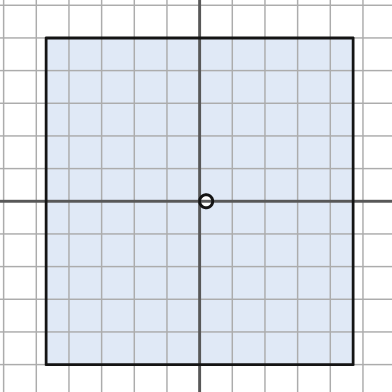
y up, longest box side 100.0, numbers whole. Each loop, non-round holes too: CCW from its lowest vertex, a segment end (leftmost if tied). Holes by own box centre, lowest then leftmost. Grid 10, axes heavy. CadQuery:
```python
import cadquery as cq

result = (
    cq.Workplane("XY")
    .moveTo(-47.0, -50.0)
    .lineTo(47.0, -50.0)
    .lineTo(47.0, 50.0)
    .lineTo(-47.0, 50.0)
    .close()
    .moveTo(2.0, 0.0)
    .circle(2.0)
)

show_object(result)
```